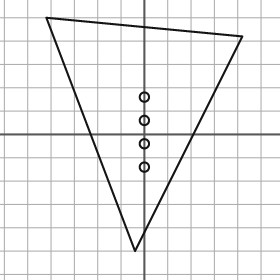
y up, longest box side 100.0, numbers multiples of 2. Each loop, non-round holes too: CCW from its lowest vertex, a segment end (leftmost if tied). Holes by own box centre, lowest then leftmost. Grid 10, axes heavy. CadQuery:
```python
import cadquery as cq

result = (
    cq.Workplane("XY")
    .moveTo(-4.0, -50.0)
    .lineTo(42.0, 42.0)
    .lineTo(-42.0, 50.0)
    .close()
    .moveTo(0.0, -14.0)
    .circle(2.0)
    .moveTo(0.0, -4.0)
    .circle(2.0)
    .moveTo(0.0, 6.0)
    .circle(2.0)
    .moveTo(0.0, 16.0)
    .circle(2.0)
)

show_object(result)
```